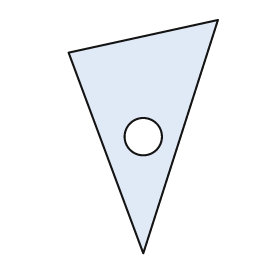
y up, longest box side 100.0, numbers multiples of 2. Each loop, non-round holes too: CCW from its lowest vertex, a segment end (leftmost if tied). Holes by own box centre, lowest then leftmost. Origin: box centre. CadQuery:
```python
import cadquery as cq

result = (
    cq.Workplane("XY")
    .moveTo(0.0, -50.0)
    .lineTo(32.0, 50.0)
    .lineTo(-32.0, 36.0)
    .close()
    .moveTo(0.0, 0.0)
    .circle(8.0)
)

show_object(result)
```